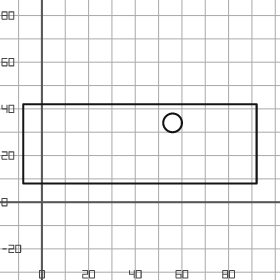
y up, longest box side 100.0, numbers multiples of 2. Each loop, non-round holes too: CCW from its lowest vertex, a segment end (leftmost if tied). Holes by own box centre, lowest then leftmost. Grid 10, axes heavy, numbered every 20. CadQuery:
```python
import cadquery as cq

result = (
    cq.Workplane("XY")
    .moveTo(-8.0, 8.0)
    .lineTo(92.0, 8.0)
    .lineTo(92.0, 42.0)
    .lineTo(-8.0, 42.0)
    .close()
    .moveTo(56.0, 34.0)
    .circle(4.0)
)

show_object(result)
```